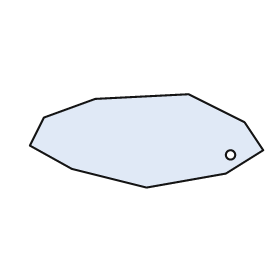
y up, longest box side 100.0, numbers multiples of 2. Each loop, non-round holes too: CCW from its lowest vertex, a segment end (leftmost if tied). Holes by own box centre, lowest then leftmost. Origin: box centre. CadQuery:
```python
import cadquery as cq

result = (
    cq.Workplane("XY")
    .moveTo(0.0, -20.0)
    .lineTo(34.0, -14.0)
    .lineTo(50.0, -4.0)
    .lineTo(42.0, 8.0)
    .lineTo(18.0, 20.0)
    .lineTo(-22.0, 18.0)
    .lineTo(-44.0, 10.0)
    .lineTo(-50.0, -2.0)
    .lineTo(-32.0, -12.0)
    .close()
    .moveTo(36.0, -6.0)
    .circle(2.0)
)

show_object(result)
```